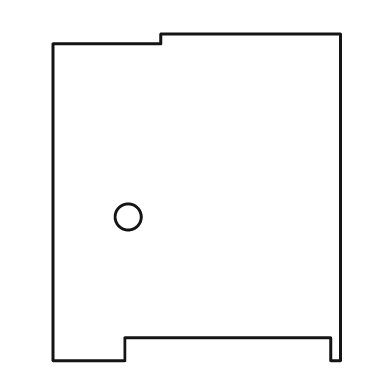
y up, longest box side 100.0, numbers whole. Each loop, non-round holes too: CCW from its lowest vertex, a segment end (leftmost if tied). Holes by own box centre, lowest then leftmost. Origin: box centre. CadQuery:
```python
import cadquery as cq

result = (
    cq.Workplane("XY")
    .moveTo(-44.0, -50.0)
    .lineTo(-22.0, -50.0)
    .lineTo(-22.0, -43.0)
    .lineTo(41.0, -43.0)
    .lineTo(41.0, -50.0)
    .lineTo(44.0, -50.0)
    .lineTo(44.0, 50.0)
    .lineTo(-11.0, 50.0)
    .lineTo(-11.0, 47.0)
    .lineTo(-44.0, 47.0)
    .close()
    .moveTo(-21.0, -6.0)
    .circle(4.0)
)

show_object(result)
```